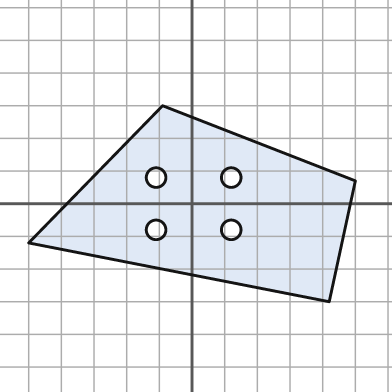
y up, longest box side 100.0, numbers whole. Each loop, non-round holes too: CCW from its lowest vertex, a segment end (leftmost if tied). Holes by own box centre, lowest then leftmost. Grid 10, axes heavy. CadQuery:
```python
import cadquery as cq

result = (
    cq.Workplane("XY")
    .moveTo(42.0, -30.0)
    .lineTo(50.0, 7.0)
    .lineTo(-9.0, 30.0)
    .lineTo(-50.0, -12.0)
    .close()
    .moveTo(-11.0, -8.0)
    .circle(3.0)
    .moveTo(12.0, -8.0)
    .circle(3.0)
    .moveTo(-11.0, 8.0)
    .circle(3.0)
    .moveTo(12.0, 8.0)
    .circle(3.0)
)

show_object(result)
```